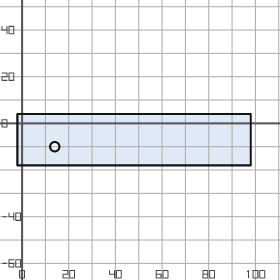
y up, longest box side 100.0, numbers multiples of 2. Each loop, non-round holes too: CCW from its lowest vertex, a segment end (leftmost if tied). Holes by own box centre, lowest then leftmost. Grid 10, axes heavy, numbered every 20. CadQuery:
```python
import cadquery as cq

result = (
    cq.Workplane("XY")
    .moveTo(-2.0, -18.0)
    .lineTo(98.0, -18.0)
    .lineTo(98.0, 4.0)
    .lineTo(-2.0, 4.0)
    .close()
    .moveTo(14.0, -10.0)
    .circle(2.0)
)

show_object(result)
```